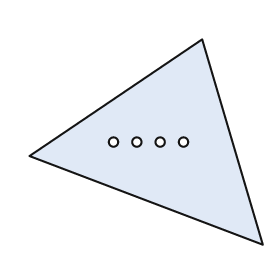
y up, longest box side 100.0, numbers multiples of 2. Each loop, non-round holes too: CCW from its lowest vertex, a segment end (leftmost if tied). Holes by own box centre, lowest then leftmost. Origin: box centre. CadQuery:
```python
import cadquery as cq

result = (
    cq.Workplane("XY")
    .moveTo(50.0, -44.0)
    .lineTo(24.0, 44.0)
    .lineTo(-50.0, -6.0)
    .close()
    .moveTo(-14.0, 0.0)
    .circle(2.0)
    .moveTo(-4.0, 0.0)
    .circle(2.0)
    .moveTo(6.0, 0.0)
    .circle(2.0)
    .moveTo(16.0, 0.0)
    .circle(2.0)
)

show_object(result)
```